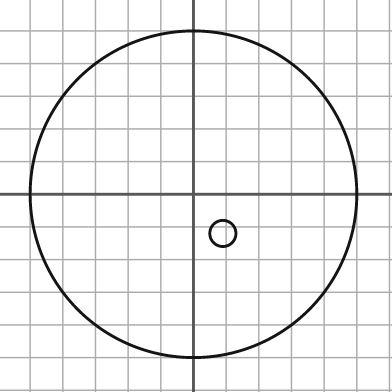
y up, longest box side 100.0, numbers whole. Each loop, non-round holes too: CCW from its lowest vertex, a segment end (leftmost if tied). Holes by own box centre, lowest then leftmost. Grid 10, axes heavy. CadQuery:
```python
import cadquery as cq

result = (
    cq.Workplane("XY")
    .moveTo(0.0, 0.0)
    .circle(50.0)
    .moveTo(9.0, -12.0)
    .circle(4.0)
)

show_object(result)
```